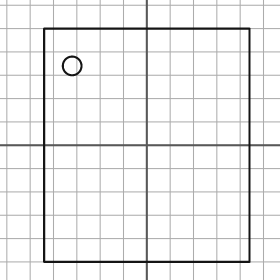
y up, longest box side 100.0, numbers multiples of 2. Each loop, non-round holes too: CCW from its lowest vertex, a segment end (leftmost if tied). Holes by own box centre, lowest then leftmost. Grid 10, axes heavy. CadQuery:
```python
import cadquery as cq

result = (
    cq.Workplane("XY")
    .moveTo(-44.0, -50.0)
    .lineTo(44.0, -50.0)
    .lineTo(44.0, 50.0)
    .lineTo(-44.0, 50.0)
    .close()
    .moveTo(-32.0, 34.0)
    .circle(4.0)
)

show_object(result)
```